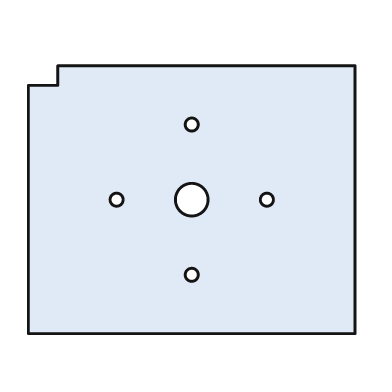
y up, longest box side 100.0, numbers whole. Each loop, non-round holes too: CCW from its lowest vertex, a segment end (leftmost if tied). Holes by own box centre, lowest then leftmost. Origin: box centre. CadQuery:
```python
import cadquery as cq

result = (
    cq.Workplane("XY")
    .moveTo(-50.0, -41.0)
    .lineTo(50.0, -41.0)
    .lineTo(50.0, 41.0)
    .lineTo(-41.0, 41.0)
    .lineTo(-41.0, 35.0)
    .lineTo(-50.0, 35.0)
    .close()
    .moveTo(0.0, -23.0)
    .circle(2.0)
    .moveTo(-23.0, 0.0)
    .circle(2.0)
    .moveTo(0.0, 0.0)
    .circle(5.0)
    .moveTo(23.0, 0.0)
    .circle(2.0)
    .moveTo(0.0, 23.0)
    .circle(2.0)
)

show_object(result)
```